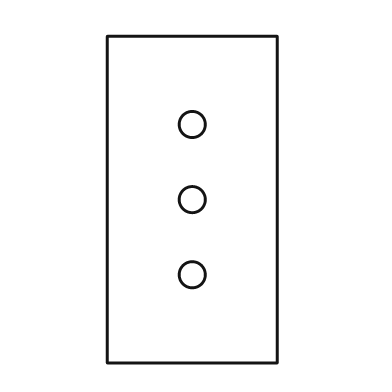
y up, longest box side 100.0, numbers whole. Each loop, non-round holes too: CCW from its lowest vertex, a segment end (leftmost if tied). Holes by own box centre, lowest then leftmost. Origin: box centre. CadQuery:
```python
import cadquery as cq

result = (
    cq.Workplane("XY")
    .moveTo(-26.0, -50.0)
    .lineTo(26.0, -50.0)
    .lineTo(26.0, 50.0)
    .lineTo(-26.0, 50.0)
    .close()
    .moveTo(0.0, -23.0)
    .circle(4.0)
    .moveTo(0.0, 0.0)
    .circle(4.0)
    .moveTo(0.0, 23.0)
    .circle(4.0)
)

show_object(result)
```